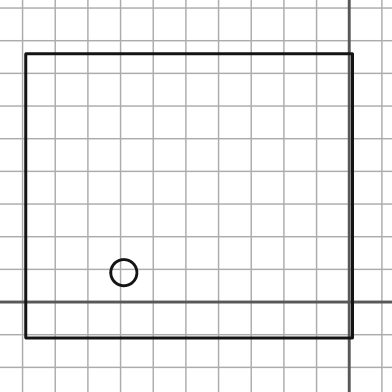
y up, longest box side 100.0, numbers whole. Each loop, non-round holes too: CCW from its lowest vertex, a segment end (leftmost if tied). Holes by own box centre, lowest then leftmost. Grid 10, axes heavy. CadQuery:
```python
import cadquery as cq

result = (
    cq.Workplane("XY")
    .moveTo(-99.0, -11.0)
    .lineTo(1.0, -11.0)
    .lineTo(1.0, 76.0)
    .lineTo(-99.0, 76.0)
    .close()
    .moveTo(-69.0, 9.0)
    .circle(4.0)
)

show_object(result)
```